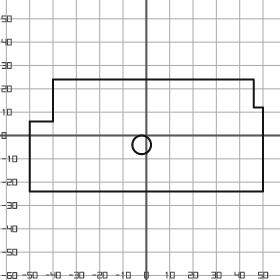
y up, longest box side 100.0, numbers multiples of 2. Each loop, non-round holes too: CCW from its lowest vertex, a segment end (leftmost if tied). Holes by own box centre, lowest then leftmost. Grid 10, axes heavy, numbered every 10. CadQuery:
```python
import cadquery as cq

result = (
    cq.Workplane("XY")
    .moveTo(-50.0, -24.0)
    .lineTo(50.0, -24.0)
    .lineTo(50.0, 12.0)
    .lineTo(46.0, 12.0)
    .lineTo(46.0, 24.0)
    .lineTo(-40.0, 24.0)
    .lineTo(-40.0, 6.0)
    .lineTo(-50.0, 6.0)
    .close()
    .moveTo(-2.0, -4.0)
    .circle(4.0)
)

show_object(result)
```